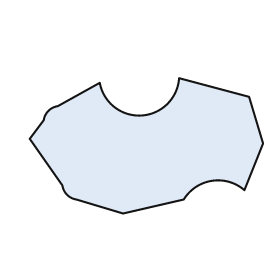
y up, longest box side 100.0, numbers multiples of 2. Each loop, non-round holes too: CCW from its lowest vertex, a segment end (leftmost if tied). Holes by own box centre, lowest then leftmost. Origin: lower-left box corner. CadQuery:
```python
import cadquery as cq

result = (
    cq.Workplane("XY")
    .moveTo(40.0, 0.0)
    .lineTo(66.0, 6.0)
    .threePointArc((78.0, 14.0), (92.0, 10.0))
    .lineTo(100.0, 30.0)
    .lineTo(94.0, 50.0)
    .lineTo(64.0, 58.0)
    .threePointArc((48.0, 42.0), (30.0, 56.0))
    .lineTo(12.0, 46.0)
    .threePointArc((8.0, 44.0), (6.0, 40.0))
    .lineTo(0.0, 32.0)
    .lineTo(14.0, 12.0)
    .threePointArc((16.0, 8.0), (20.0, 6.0))
    .close()
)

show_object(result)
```